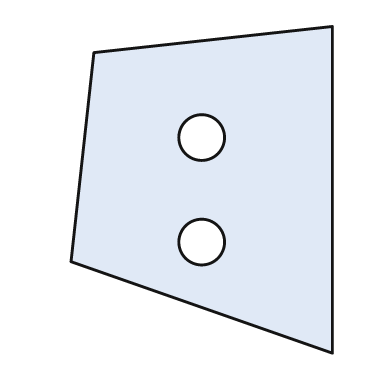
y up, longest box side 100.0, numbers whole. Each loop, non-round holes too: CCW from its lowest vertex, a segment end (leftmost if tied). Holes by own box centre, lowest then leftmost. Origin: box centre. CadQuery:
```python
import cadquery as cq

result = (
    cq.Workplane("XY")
    .moveTo(40.0, -50.0)
    .lineTo(40.0, 50.0)
    .lineTo(-33.0, 42.0)
    .lineTo(-40.0, -22.0)
    .close()
    .moveTo(0.0, -16.0)
    .circle(7.0)
    .moveTo(0.0, 16.0)
    .circle(7.0)
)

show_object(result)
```